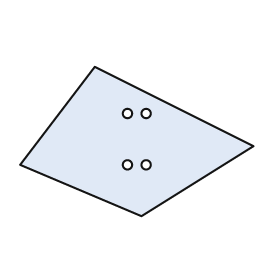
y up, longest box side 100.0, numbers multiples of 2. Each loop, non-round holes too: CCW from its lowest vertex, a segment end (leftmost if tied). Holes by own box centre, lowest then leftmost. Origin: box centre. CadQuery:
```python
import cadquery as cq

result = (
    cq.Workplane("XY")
    .moveTo(2.0, -32.0)
    .lineTo(50.0, -2.0)
    .lineTo(-18.0, 32.0)
    .lineTo(-50.0, -10.0)
    .close()
    .moveTo(-4.0, -10.0)
    .circle(2.0)
    .moveTo(4.0, -10.0)
    .circle(2.0)
    .moveTo(-4.0, 12.0)
    .circle(2.0)
    .moveTo(4.0, 12.0)
    .circle(2.0)
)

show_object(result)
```